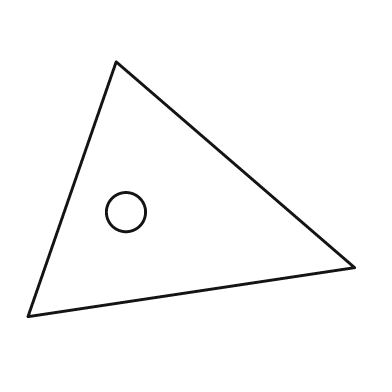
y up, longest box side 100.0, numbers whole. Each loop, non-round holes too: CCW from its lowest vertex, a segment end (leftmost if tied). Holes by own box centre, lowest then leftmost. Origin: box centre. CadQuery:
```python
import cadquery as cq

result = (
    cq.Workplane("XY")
    .moveTo(-50.0, -39.0)
    .lineTo(50.0, -24.0)
    .lineTo(-23.0, 39.0)
    .close()
    .moveTo(-20.0, -7.0)
    .circle(6.0)
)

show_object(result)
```